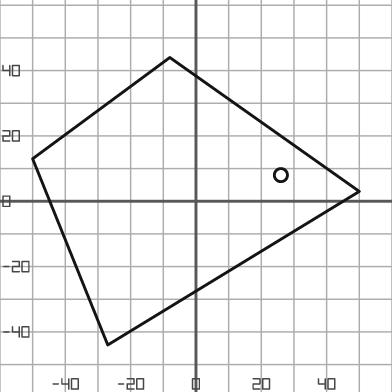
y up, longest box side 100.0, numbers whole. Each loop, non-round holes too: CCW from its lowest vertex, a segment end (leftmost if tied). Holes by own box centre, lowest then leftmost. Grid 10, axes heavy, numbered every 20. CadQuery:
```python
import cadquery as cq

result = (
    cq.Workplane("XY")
    .moveTo(-27.0, -44.0)
    .lineTo(50.0, 3.0)
    .lineTo(-8.0, 44.0)
    .lineTo(-50.0, 13.0)
    .close()
    .moveTo(26.0, 8.0)
    .circle(2.0)
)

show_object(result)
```